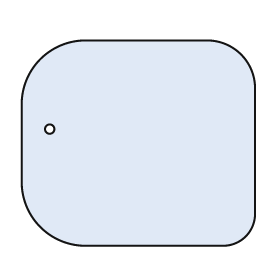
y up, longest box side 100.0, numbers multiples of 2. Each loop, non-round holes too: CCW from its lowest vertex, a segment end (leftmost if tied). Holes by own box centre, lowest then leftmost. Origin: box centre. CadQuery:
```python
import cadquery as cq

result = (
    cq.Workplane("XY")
    .moveTo(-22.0, -44.0)
    .lineTo(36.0, -44.0)
    .threePointArc((46.0, -40.0), (50.0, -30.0))
    .lineTo(50.0, 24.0)
    .threePointArc((44.0, 38.0), (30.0, 44.0))
    .lineTo(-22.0, 44.0)
    .threePointArc((-42.0, 36.0), (-50.0, 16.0))
    .lineTo(-50.0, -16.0)
    .threePointArc((-42.0, -36.0), (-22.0, -44.0))
    .close()
    .moveTo(-38.0, 6.0)
    .circle(2.0)
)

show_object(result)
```